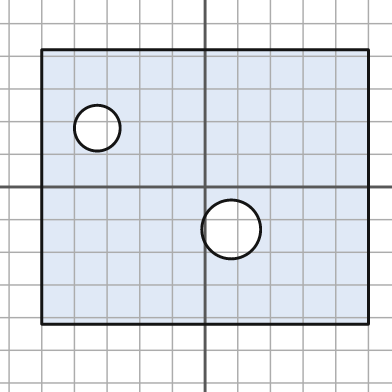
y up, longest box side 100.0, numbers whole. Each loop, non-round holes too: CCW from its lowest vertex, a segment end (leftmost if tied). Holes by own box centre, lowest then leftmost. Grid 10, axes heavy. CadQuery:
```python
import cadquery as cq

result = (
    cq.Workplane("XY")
    .moveTo(-50.0, -42.0)
    .lineTo(50.0, -42.0)
    .lineTo(50.0, 42.0)
    .lineTo(-50.0, 42.0)
    .close()
    .moveTo(8.0, -13.0)
    .circle(9.0)
    .moveTo(-33.0, 18.0)
    .circle(7.0)
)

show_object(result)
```